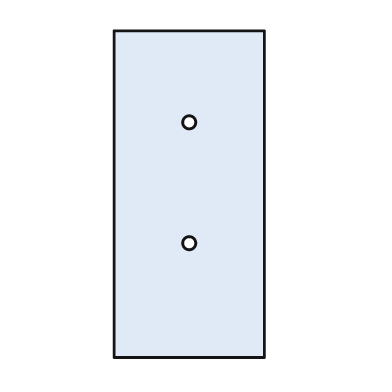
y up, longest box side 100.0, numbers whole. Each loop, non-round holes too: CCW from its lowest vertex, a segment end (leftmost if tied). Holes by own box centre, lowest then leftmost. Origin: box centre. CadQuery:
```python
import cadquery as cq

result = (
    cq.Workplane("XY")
    .moveTo(-23.0, -50.0)
    .lineTo(23.0, -50.0)
    .lineTo(23.0, 50.0)
    .lineTo(-23.0, 50.0)
    .close()
    .moveTo(0.0, -15.0)
    .circle(2.0)
    .moveTo(0.0, 22.0)
    .circle(2.0)
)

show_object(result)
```